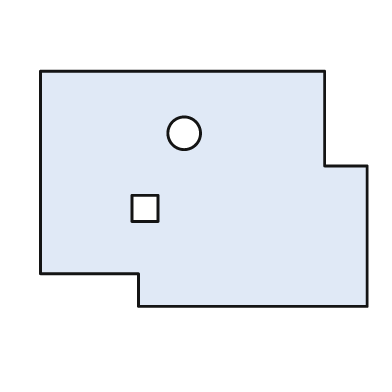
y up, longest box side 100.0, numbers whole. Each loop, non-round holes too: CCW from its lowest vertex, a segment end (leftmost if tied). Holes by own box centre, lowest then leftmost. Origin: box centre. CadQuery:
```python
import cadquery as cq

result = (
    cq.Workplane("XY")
    .moveTo(-20.0, -36.0)
    .lineTo(50.0, -36.0)
    .lineTo(50.0, 7.0)
    .lineTo(37.0, 7.0)
    .lineTo(37.0, 36.0)
    .lineTo(-50.0, 36.0)
    .lineTo(-50.0, -26.0)
    .lineTo(-20.0, -26.0)
    .close()
    .moveTo(-22.0, -10.0)
    .lineTo(-14.0, -10.0)
    .lineTo(-14.0, -2.0)
    .lineTo(-22.0, -2.0)
    .close()
    .moveTo(-6.0, 17.0)
    .circle(5.0)
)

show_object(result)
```